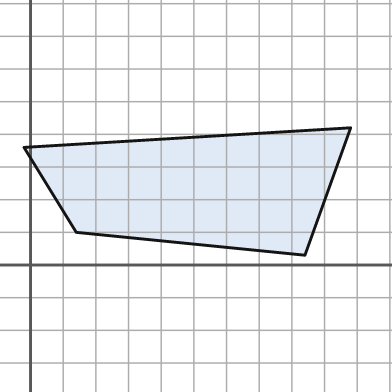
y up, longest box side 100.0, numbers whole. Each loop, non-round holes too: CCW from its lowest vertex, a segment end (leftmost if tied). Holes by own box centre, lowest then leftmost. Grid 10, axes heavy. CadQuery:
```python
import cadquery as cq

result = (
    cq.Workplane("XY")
    .moveTo(84.0, 3.0)
    .lineTo(98.0, 42.0)
    .lineTo(-2.0, 36.0)
    .lineTo(14.0, 10.0)
    .close()
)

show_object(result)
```